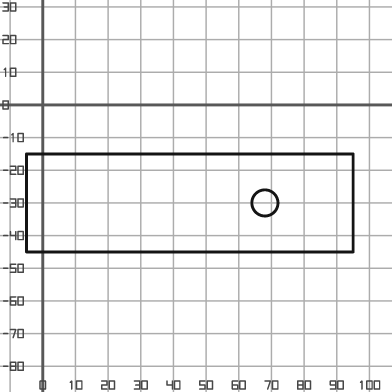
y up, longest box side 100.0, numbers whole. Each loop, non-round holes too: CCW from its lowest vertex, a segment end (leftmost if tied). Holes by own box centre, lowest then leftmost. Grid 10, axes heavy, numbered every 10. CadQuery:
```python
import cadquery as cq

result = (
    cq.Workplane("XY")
    .moveTo(-5.0, -45.0)
    .lineTo(95.0, -45.0)
    .lineTo(95.0, -15.0)
    .lineTo(-5.0, -15.0)
    .close()
    .moveTo(68.0, -30.0)
    .circle(4.0)
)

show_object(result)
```